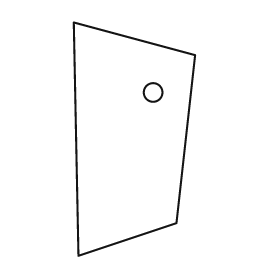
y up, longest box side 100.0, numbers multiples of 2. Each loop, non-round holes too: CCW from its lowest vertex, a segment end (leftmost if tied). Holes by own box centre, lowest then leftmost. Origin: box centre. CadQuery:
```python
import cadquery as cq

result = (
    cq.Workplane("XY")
    .moveTo(-24.0, -50.0)
    .lineTo(18.0, -36.0)
    .lineTo(26.0, 36.0)
    .lineTo(-26.0, 50.0)
    .close()
    .moveTo(8.0, 20.0)
    .circle(4.0)
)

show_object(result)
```